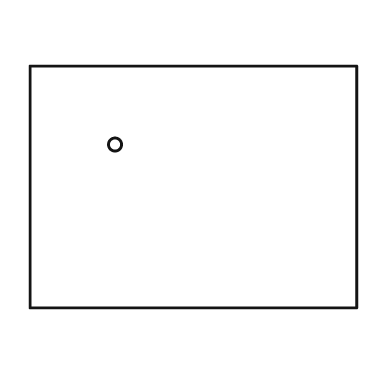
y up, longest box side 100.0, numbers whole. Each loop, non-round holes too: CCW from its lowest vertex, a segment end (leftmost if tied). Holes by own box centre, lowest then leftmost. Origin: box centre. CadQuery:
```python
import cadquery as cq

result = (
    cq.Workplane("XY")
    .moveTo(-50.0, -37.0)
    .lineTo(50.0, -37.0)
    .lineTo(50.0, 37.0)
    .lineTo(-50.0, 37.0)
    .close()
    .moveTo(-24.0, 13.0)
    .circle(2.0)
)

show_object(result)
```